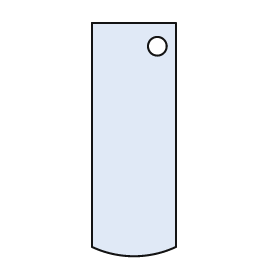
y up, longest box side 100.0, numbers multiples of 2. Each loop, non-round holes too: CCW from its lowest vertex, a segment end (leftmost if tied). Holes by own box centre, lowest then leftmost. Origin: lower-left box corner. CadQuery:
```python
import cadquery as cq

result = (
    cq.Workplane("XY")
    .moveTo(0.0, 4.0)
    .threePointArc((18.0, 0.0), (36.0, 4.0))
    .lineTo(36.0, 100.0)
    .lineTo(0.0, 100.0)
    .close()
    .moveTo(28.0, 90.0)
    .circle(4.0)
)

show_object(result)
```